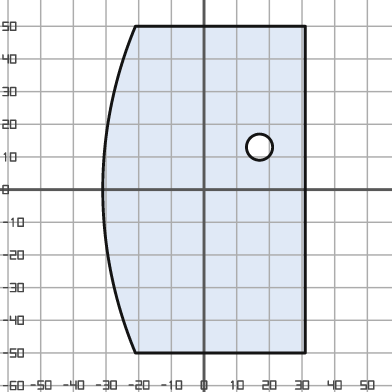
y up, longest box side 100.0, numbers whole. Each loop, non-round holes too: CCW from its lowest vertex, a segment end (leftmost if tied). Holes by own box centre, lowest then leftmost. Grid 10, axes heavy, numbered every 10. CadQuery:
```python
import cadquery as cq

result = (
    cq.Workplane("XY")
    .moveTo(-21.0, -50.0)
    .lineTo(31.0, -50.0)
    .lineTo(31.0, 50.0)
    .lineTo(-21.0, 50.0)
    .threePointArc((-31.0, 0.0), (-21.0, -50.0))
    .close()
    .moveTo(17.0, 13.0)
    .circle(4.0)
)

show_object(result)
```